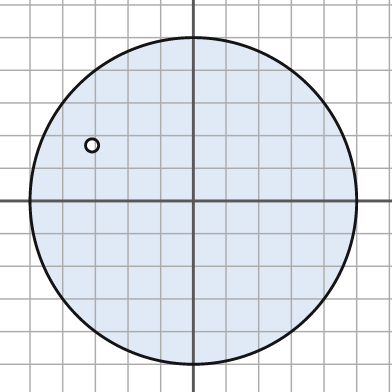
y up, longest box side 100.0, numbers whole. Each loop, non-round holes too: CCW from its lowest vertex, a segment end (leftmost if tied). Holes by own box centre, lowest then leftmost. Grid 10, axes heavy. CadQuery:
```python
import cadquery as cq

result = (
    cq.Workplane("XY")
    .moveTo(0.0, 0.0)
    .circle(50.0)
    .moveTo(-31.0, 17.0)
    .circle(2.0)
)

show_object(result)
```